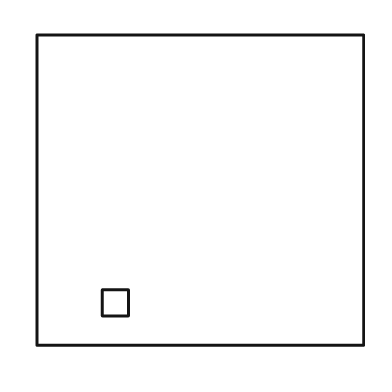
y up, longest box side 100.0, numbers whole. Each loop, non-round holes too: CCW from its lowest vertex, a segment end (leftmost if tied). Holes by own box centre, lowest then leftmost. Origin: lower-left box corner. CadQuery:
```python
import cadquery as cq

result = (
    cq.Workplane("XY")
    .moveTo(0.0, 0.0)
    .lineTo(100.0, 0.0)
    .lineTo(100.0, 95.0)
    .lineTo(0.0, 95.0)
    .close()
    .moveTo(20.0, 9.0)
    .lineTo(28.0, 9.0)
    .lineTo(28.0, 17.0)
    .lineTo(20.0, 17.0)
    .close()
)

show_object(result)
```